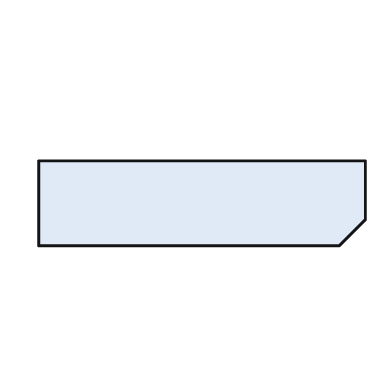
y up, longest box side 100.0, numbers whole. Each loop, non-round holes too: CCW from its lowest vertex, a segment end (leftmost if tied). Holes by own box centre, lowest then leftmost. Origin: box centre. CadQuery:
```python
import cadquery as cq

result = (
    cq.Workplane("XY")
    .moveTo(-50.0, -13.0)
    .lineTo(42.0, -13.0)
    .lineTo(50.0, -5.0)
    .lineTo(50.0, 13.0)
    .lineTo(-50.0, 13.0)
    .close()
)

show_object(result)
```